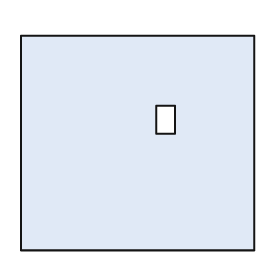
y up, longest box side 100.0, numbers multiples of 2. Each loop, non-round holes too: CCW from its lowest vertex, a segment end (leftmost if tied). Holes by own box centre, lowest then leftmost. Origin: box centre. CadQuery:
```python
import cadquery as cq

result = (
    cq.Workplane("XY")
    .moveTo(-50.0, -46.0)
    .lineTo(50.0, -46.0)
    .lineTo(50.0, 46.0)
    .lineTo(-50.0, 46.0)
    .close()
    .moveTo(8.0, 4.0)
    .lineTo(16.0, 4.0)
    .lineTo(16.0, 16.0)
    .lineTo(8.0, 16.0)
    .close()
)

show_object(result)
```